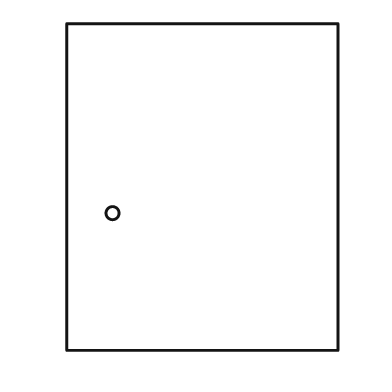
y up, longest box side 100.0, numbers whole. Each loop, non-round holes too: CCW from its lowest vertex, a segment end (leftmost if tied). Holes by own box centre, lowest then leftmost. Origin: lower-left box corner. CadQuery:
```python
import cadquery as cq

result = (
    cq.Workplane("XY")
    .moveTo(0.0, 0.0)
    .lineTo(83.0, 0.0)
    .lineTo(83.0, 100.0)
    .lineTo(0.0, 100.0)
    .close()
    .moveTo(14.0, 42.0)
    .circle(2.0)
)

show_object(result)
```